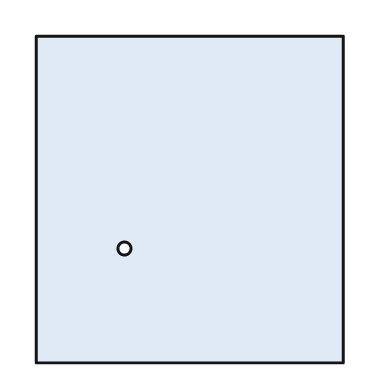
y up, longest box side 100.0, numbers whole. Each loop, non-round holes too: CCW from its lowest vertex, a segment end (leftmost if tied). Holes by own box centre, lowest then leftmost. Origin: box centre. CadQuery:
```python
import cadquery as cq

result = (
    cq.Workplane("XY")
    .moveTo(-47.0, -50.0)
    .lineTo(47.0, -50.0)
    .lineTo(47.0, 50.0)
    .lineTo(-47.0, 50.0)
    .close()
    .moveTo(-20.0, -15.0)
    .circle(2.0)
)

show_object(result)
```